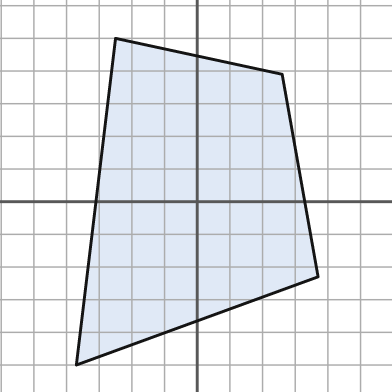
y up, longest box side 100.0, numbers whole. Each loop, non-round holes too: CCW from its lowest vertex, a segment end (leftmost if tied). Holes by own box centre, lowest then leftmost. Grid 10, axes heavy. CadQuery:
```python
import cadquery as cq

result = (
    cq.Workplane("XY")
    .moveTo(-37.0, -50.0)
    .lineTo(37.0, -23.0)
    .lineTo(26.0, 39.0)
    .lineTo(-25.0, 50.0)
    .close()
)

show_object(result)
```